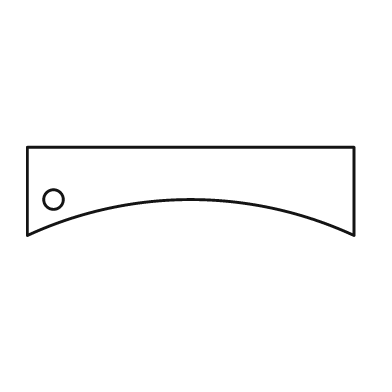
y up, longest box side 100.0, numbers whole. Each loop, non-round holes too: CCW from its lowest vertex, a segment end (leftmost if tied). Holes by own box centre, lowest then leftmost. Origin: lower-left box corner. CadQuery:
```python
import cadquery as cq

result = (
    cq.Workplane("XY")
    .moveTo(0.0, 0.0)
    .threePointArc((50.0, 11.0), (100.0, 0.0))
    .lineTo(100.0, 27.0)
    .lineTo(0.0, 27.0)
    .close()
    .moveTo(8.0, 11.0)
    .circle(3.0)
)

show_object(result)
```